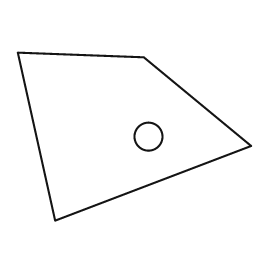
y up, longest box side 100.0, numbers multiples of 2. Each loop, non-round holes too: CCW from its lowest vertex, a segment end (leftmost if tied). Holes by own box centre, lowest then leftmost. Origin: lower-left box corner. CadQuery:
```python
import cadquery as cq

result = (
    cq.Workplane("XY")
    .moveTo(16.0, 0.0)
    .lineTo(100.0, 32.0)
    .lineTo(54.0, 70.0)
    .lineTo(0.0, 72.0)
    .close()
    .moveTo(56.0, 36.0)
    .circle(6.0)
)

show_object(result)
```